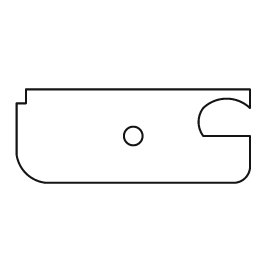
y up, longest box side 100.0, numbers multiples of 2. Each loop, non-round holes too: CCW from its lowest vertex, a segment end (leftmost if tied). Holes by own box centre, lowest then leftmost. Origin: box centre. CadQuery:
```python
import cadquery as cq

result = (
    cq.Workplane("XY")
    .moveTo(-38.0, -20.0)
    .lineTo(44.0, -20.0)
    .threePointArc((48.0, -18.0), (50.0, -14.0))
    .lineTo(50.0, 0.0)
    .lineTo(30.0, 0.0)
    .threePointArc((28.0, 6.0), (30.0, 12.0))
    .threePointArc((40.0, 16.0), (50.0, 12.0))
    .lineTo(50.0, 20.0)
    .lineTo(-46.0, 20.0)
    .lineTo(-46.0, 14.0)
    .lineTo(-50.0, 14.0)
    .lineTo(-50.0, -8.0)
    .threePointArc((-46.0, -16.0), (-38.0, -20.0))
    .close()
    .moveTo(0.0, 0.0)
    .circle(4.0)
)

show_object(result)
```